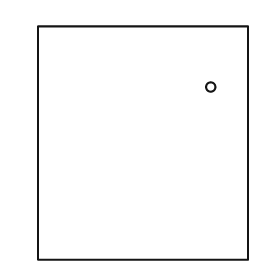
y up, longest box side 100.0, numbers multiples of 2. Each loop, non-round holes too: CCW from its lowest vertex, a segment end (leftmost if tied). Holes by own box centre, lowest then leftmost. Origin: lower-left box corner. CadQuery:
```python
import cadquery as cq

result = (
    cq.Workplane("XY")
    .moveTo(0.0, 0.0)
    .lineTo(90.0, 0.0)
    .lineTo(90.0, 100.0)
    .lineTo(0.0, 100.0)
    .close()
    .moveTo(74.0, 74.0)
    .circle(2.0)
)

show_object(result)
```